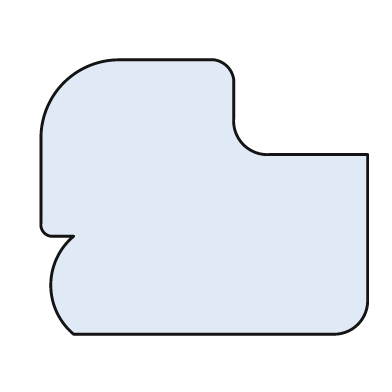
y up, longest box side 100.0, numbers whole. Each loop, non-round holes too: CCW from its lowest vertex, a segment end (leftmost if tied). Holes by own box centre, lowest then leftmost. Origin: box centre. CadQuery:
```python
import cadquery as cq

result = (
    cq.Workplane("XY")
    .moveTo(-40.0, -42.0)
    .lineTo(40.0, -42.0)
    .threePointArc((47.0, -39.0), (50.0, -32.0))
    .lineTo(50.0, 13.0)
    .lineTo(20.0, 13.0)
    .threePointArc((12.0, 16.0), (9.0, 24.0))
    .lineTo(9.0, 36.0)
    .threePointArc((7.0, 40.0), (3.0, 42.0))
    .lineTo(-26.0, 42.0)
    .threePointArc((-43.0, 35.0), (-50.0, 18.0))
    .lineTo(-50.0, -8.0)
    .threePointArc((-49.0, -11.0), (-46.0, -12.0))
    .lineTo(-40.0, -12.0)
    .threePointArc((-47.0, -27.0), (-40.0, -42.0))
    .close()
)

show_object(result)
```